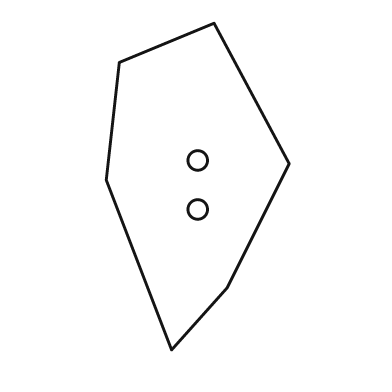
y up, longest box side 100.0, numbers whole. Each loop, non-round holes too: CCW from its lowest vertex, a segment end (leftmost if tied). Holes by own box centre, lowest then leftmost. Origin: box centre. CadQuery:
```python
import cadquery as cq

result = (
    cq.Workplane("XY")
    .moveTo(-8.0, -50.0)
    .lineTo(9.0, -31.0)
    .lineTo(28.0, 7.0)
    .lineTo(5.0, 50.0)
    .lineTo(-24.0, 38.0)
    .lineTo(-28.0, 2.0)
    .close()
    .moveTo(0.0, -7.0)
    .circle(3.0)
    .moveTo(0.0, 8.0)
    .circle(3.0)
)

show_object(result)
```